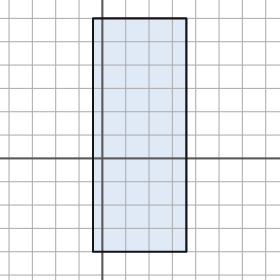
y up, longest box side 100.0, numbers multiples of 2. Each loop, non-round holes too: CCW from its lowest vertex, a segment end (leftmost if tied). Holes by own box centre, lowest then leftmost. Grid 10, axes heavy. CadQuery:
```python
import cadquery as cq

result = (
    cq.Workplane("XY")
    .moveTo(-4.0, -40.0)
    .lineTo(36.0, -40.0)
    .lineTo(36.0, 60.0)
    .lineTo(-4.0, 60.0)
    .close()
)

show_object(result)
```